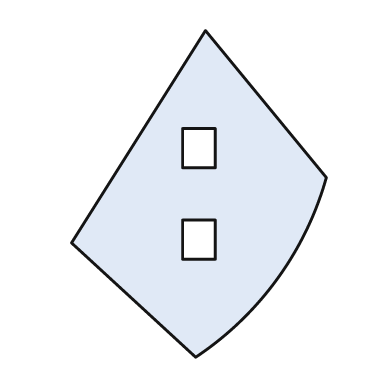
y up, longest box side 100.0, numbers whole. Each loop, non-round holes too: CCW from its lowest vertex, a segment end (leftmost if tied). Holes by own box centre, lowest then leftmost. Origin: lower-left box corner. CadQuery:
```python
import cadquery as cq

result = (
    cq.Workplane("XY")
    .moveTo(38.0, 0.0)
    .threePointArc((63.0, 24.0), (78.0, 55.0))
    .lineTo(41.0, 100.0)
    .lineTo(0.0, 35.0)
    .close()
    .moveTo(34.0, 30.0)
    .lineTo(44.0, 30.0)
    .lineTo(44.0, 42.0)
    .lineTo(34.0, 42.0)
    .close()
    .moveTo(34.0, 58.0)
    .lineTo(44.0, 58.0)
    .lineTo(44.0, 70.0)
    .lineTo(34.0, 70.0)
    .close()
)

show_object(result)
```